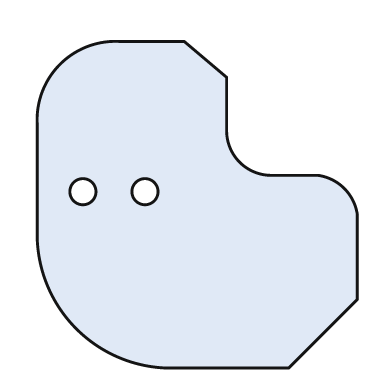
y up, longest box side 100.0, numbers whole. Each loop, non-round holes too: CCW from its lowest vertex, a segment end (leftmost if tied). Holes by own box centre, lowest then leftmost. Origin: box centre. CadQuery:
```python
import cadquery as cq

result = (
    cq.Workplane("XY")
    .moveTo(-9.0, -50.0)
    .lineTo(28.0, -50.0)
    .lineTo(49.0, -29.0)
    .lineTo(49.0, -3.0)
    .threePointArc((45.0, 5.0), (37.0, 9.0))
    .lineTo(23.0, 9.0)
    .threePointArc((13.0, 13.0), (9.0, 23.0))
    .lineTo(9.0, 39.0)
    .lineTo(-4.0, 50.0)
    .lineTo(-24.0, 50.0)
    .threePointArc((-42.0, 43.0), (-49.0, 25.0))
    .lineTo(-49.0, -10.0)
    .threePointArc((-37.0, -38.0), (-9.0, -50.0))
    .close()
    .moveTo(-35.0, 4.0)
    .circle(4.0)
    .moveTo(-16.0, 4.0)
    .circle(4.0)
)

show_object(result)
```